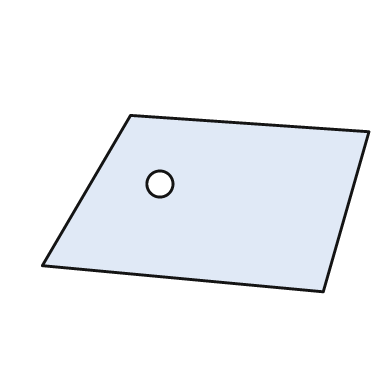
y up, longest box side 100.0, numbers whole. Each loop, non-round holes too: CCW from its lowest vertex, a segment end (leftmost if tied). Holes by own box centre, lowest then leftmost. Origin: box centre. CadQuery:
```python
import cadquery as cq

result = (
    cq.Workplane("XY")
    .moveTo(36.0, -27.0)
    .lineTo(50.0, 22.0)
    .lineTo(-23.0, 27.0)
    .lineTo(-50.0, -19.0)
    .close()
    .moveTo(-14.0, 6.0)
    .circle(4.0)
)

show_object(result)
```